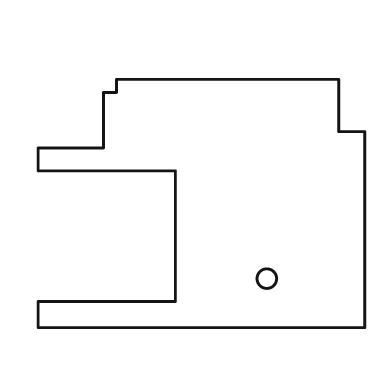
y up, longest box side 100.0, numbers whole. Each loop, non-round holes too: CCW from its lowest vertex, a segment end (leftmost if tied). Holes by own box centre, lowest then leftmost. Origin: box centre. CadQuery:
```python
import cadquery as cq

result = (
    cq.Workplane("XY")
    .moveTo(-50.0, -38.0)
    .lineTo(50.0, -38.0)
    .lineTo(50.0, 22.0)
    .lineTo(42.0, 22.0)
    .lineTo(42.0, 38.0)
    .lineTo(-26.0, 38.0)
    .lineTo(-26.0, 34.0)
    .lineTo(-30.0, 34.0)
    .lineTo(-30.0, 17.0)
    .lineTo(-50.0, 17.0)
    .lineTo(-50.0, 10.0)
    .lineTo(-8.0, 10.0)
    .lineTo(-8.0, -30.0)
    .lineTo(-50.0, -30.0)
    .close()
    .moveTo(20.0, -23.0)
    .circle(3.0)
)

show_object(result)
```